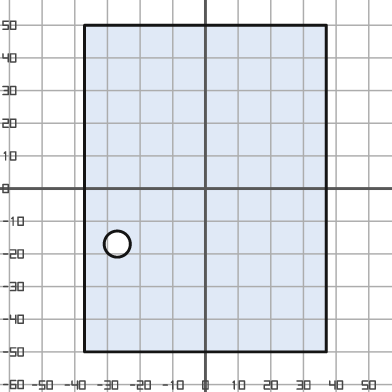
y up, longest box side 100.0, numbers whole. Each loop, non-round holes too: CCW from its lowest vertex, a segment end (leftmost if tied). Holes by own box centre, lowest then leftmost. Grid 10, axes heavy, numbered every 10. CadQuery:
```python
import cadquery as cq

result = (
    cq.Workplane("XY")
    .moveTo(-37.0, -50.0)
    .lineTo(37.0, -50.0)
    .lineTo(37.0, 50.0)
    .lineTo(-37.0, 50.0)
    .close()
    .moveTo(-27.0, -17.0)
    .circle(4.0)
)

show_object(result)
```